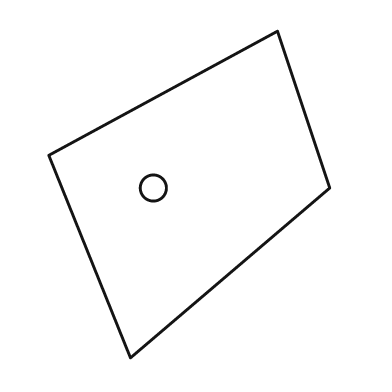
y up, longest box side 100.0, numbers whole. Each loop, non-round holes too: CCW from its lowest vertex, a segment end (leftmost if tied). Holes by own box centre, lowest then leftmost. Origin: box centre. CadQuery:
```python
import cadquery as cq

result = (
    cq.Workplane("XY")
    .moveTo(-18.0, -50.0)
    .lineTo(43.0, 2.0)
    .lineTo(27.0, 50.0)
    .lineTo(-43.0, 12.0)
    .close()
    .moveTo(-11.0, 2.0)
    .circle(4.0)
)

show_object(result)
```